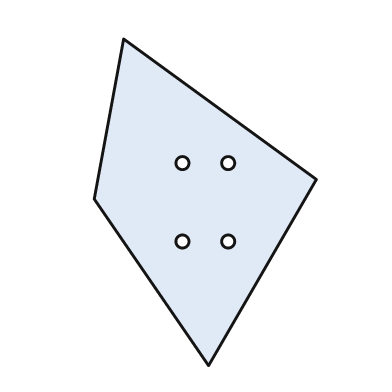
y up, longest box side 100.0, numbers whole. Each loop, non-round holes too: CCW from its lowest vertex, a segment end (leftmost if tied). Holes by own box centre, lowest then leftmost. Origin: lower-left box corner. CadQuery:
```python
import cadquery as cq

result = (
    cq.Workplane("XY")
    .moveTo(35.0, 0.0)
    .lineTo(68.0, 57.0)
    .lineTo(9.0, 100.0)
    .lineTo(0.0, 51.0)
    .close()
    .moveTo(27.0, 38.0)
    .circle(2.0)
    .moveTo(41.0, 38.0)
    .circle(2.0)
    .moveTo(27.0, 62.0)
    .circle(2.0)
    .moveTo(41.0, 62.0)
    .circle(2.0)
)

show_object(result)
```